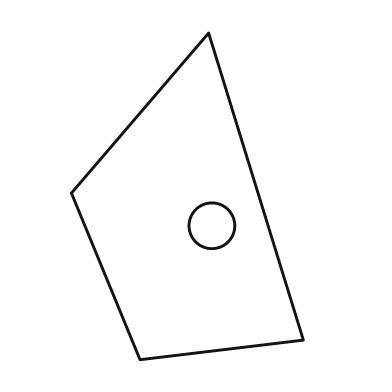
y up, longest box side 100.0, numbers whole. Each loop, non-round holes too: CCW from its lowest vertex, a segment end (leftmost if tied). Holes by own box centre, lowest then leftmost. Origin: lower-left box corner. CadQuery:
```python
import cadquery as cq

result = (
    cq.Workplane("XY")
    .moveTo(21.0, 0.0)
    .lineTo(71.0, 6.0)
    .lineTo(42.0, 100.0)
    .lineTo(0.0, 51.0)
    .close()
    .moveTo(43.0, 41.0)
    .circle(7.0)
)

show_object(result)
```